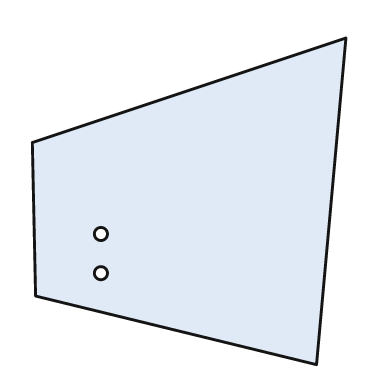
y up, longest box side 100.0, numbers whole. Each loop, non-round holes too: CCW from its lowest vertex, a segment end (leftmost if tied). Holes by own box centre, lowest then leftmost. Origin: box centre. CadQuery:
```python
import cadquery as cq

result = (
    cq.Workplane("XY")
    .moveTo(39.0, -50.0)
    .lineTo(48.0, 50.0)
    .lineTo(-48.0, 18.0)
    .lineTo(-47.0, -29.0)
    .close()
    .moveTo(-27.0, -22.0)
    .circle(2.0)
    .moveTo(-27.0, -10.0)
    .circle(2.0)
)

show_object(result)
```